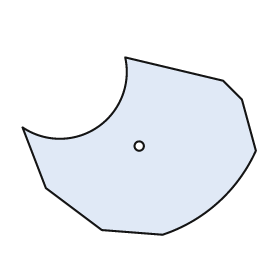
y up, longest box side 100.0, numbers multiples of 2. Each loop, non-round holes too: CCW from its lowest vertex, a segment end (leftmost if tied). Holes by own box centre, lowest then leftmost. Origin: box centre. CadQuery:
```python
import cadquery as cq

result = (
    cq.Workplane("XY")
    .moveTo(10.0, -38.0)
    .threePointArc((34.0, -24.0), (50.0, -2.0))
    .lineTo(44.0, 20.0)
    .lineTo(36.0, 28.0)
    .lineTo(-6.0, 38.0)
    .threePointArc((-18.0, 8.0), (-50.0, 8.0))
    .lineTo(-40.0, -18.0)
    .lineTo(-16.0, -36.0)
    .close()
    .moveTo(0.0, 0.0)
    .circle(2.0)
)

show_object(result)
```